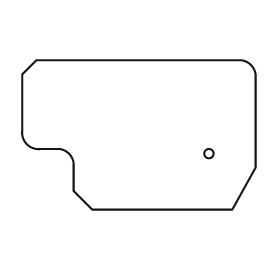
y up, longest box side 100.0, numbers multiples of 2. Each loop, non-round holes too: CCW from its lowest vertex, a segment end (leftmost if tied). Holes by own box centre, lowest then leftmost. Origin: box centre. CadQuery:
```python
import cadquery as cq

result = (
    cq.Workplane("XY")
    .moveTo(-20.0, -32.0)
    .lineTo(40.0, -32.0)
    .lineTo(50.0, -14.0)
    .lineTo(50.0, 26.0)
    .threePointArc((48.0, 30.0), (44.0, 32.0))
    .lineTo(-44.0, 32.0)
    .lineTo(-50.0, 26.0)
    .lineTo(-50.0, 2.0)
    .threePointArc((-48.0, -4.0), (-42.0, -6.0))
    .lineTo(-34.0, -6.0)
    .threePointArc((-30.0, -8.0), (-28.0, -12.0))
    .lineTo(-28.0, -24.0)
    .close()
    .moveTo(30.0, -8.0)
    .circle(2.0)
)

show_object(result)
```